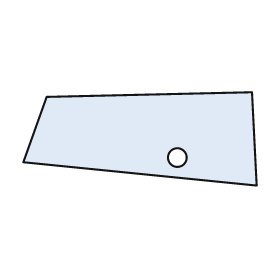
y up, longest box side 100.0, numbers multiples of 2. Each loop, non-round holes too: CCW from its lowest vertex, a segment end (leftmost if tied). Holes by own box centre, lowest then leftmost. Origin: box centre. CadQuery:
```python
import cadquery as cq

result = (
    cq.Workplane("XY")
    .moveTo(50.0, -20.0)
    .lineTo(48.0, 20.0)
    .lineTo(-40.0, 18.0)
    .lineTo(-50.0, -10.0)
    .close()
    .moveTo(16.0, -8.0)
    .circle(4.0)
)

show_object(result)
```